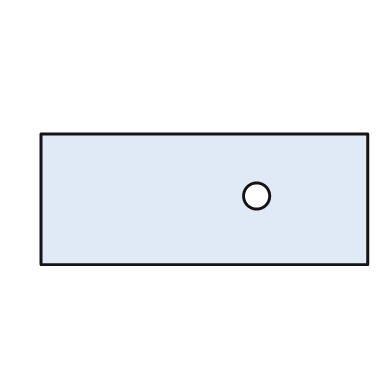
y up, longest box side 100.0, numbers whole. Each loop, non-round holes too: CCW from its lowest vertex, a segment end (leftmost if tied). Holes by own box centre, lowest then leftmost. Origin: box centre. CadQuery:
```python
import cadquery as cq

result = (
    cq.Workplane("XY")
    .moveTo(-50.0, -20.0)
    .lineTo(50.0, -20.0)
    .lineTo(50.0, 20.0)
    .lineTo(-50.0, 20.0)
    .close()
    .moveTo(16.0, 1.0)
    .circle(4.0)
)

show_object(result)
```